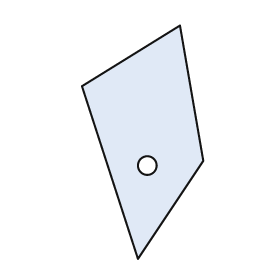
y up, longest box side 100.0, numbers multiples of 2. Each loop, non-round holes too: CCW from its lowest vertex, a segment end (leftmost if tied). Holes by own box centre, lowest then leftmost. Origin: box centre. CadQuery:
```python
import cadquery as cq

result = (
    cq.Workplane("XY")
    .moveTo(-2.0, -50.0)
    .lineTo(26.0, -8.0)
    .lineTo(16.0, 50.0)
    .lineTo(-26.0, 24.0)
    .close()
    .moveTo(2.0, -10.0)
    .circle(4.0)
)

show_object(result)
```